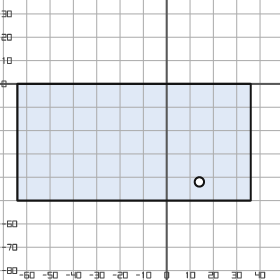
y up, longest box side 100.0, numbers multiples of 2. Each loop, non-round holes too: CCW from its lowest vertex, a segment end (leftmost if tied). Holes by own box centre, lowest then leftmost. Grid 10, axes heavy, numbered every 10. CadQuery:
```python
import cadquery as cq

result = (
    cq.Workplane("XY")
    .moveTo(-64.0, -50.0)
    .lineTo(36.0, -50.0)
    .lineTo(36.0, 0.0)
    .lineTo(-64.0, 0.0)
    .close()
    .moveTo(14.0, -42.0)
    .circle(2.0)
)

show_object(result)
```